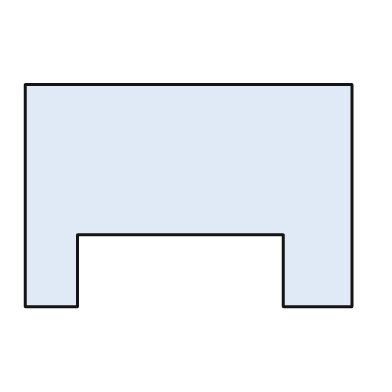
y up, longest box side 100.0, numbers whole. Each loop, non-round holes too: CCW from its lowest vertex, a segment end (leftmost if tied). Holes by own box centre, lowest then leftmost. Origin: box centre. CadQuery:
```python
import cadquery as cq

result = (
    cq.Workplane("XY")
    .moveTo(-50.0, -34.0)
    .lineTo(-34.0, -34.0)
    .lineTo(-34.0, -12.0)
    .lineTo(29.0, -12.0)
    .lineTo(29.0, -34.0)
    .lineTo(50.0, -34.0)
    .lineTo(50.0, 34.0)
    .lineTo(-50.0, 34.0)
    .close()
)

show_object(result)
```